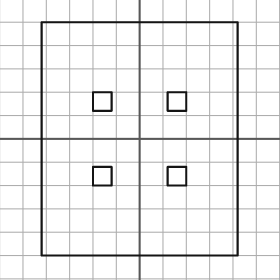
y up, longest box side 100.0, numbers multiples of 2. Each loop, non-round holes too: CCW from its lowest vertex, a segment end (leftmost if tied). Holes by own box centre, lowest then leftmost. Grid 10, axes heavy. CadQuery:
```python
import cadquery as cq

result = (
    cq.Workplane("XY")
    .moveTo(-42.0, -50.0)
    .lineTo(42.0, -50.0)
    .lineTo(42.0, 50.0)
    .lineTo(-42.0, 50.0)
    .close()
    .moveTo(-20.0, -20.0)
    .lineTo(-12.0, -20.0)
    .lineTo(-12.0, -12.0)
    .lineTo(-20.0, -12.0)
    .close()
    .moveTo(12.0, -20.0)
    .lineTo(20.0, -20.0)
    .lineTo(20.0, -12.0)
    .lineTo(12.0, -12.0)
    .close()
    .moveTo(-20.0, 12.0)
    .lineTo(-12.0, 12.0)
    .lineTo(-12.0, 20.0)
    .lineTo(-20.0, 20.0)
    .close()
    .moveTo(12.0, 12.0)
    .lineTo(20.0, 12.0)
    .lineTo(20.0, 20.0)
    .lineTo(12.0, 20.0)
    .close()
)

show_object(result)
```